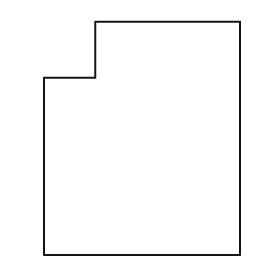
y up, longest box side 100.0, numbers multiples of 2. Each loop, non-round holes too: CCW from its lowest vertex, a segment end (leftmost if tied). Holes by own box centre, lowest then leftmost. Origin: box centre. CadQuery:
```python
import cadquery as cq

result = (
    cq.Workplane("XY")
    .moveTo(-42.0, -50.0)
    .lineTo(42.0, -50.0)
    .lineTo(42.0, 50.0)
    .lineTo(-20.0, 50.0)
    .lineTo(-20.0, 26.0)
    .lineTo(-42.0, 26.0)
    .close()
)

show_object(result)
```